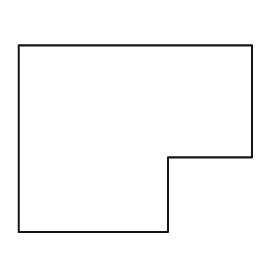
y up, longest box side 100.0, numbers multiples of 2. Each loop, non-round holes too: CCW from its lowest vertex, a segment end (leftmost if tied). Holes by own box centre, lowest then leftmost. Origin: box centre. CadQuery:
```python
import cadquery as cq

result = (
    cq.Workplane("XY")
    .moveTo(-50.0, -40.0)
    .lineTo(14.0, -40.0)
    .lineTo(14.0, -8.0)
    .lineTo(50.0, -8.0)
    .lineTo(50.0, 40.0)
    .lineTo(-50.0, 40.0)
    .close()
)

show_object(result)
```